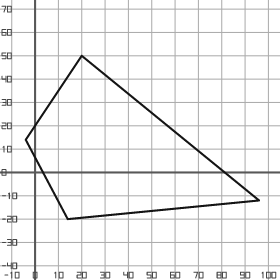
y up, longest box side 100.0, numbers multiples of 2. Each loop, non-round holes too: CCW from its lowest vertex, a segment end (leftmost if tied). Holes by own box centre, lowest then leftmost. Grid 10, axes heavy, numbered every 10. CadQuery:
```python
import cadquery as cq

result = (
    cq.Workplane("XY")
    .moveTo(14.0, -20.0)
    .lineTo(96.0, -12.0)
    .lineTo(20.0, 50.0)
    .lineTo(-4.0, 14.0)
    .close()
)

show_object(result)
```